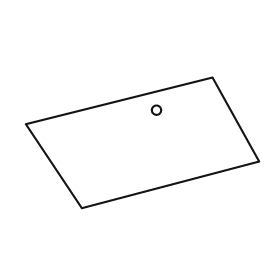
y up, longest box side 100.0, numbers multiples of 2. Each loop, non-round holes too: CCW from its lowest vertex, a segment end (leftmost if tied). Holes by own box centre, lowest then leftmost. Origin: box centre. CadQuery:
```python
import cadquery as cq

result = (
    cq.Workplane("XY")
    .moveTo(-26.0, -28.0)
    .lineTo(50.0, -8.0)
    .lineTo(30.0, 28.0)
    .lineTo(-50.0, 8.0)
    .close()
    .moveTo(6.0, 14.0)
    .circle(2.0)
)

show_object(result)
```